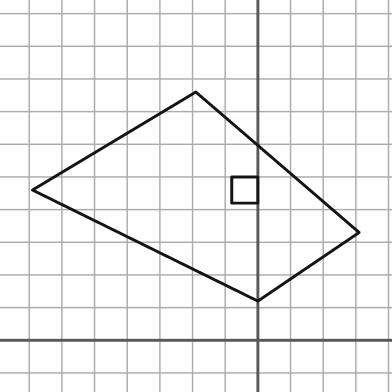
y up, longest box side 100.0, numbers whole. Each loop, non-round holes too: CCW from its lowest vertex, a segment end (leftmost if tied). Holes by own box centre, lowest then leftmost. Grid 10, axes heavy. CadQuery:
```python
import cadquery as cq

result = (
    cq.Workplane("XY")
    .moveTo(0.0, 12.0)
    .lineTo(31.0, 33.0)
    .lineTo(-19.0, 76.0)
    .lineTo(-69.0, 46.0)
    .close()
    .moveTo(-8.0, 42.0)
    .lineTo(0.0, 42.0)
    .lineTo(0.0, 50.0)
    .lineTo(-8.0, 50.0)
    .close()
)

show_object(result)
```